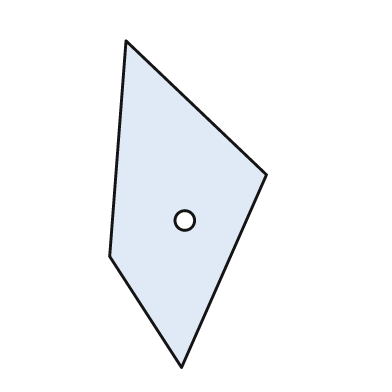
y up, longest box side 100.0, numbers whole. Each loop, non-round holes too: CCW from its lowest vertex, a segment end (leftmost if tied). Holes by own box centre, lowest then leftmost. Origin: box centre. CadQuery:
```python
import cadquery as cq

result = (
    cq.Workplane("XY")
    .moveTo(-2.0, -50.0)
    .lineTo(24.0, 9.0)
    .lineTo(-19.0, 50.0)
    .lineTo(-24.0, -16.0)
    .close()
    .moveTo(-1.0, -5.0)
    .circle(3.0)
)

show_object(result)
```